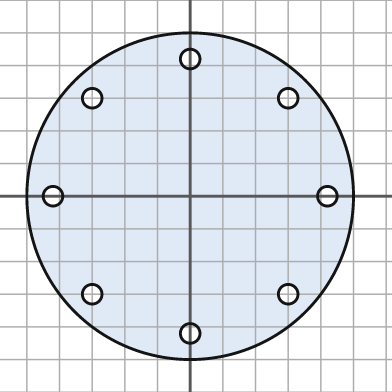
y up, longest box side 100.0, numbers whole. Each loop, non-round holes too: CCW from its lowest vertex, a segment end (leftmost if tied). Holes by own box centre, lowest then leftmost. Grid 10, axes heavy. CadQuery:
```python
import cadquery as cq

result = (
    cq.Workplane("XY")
    .moveTo(0.0, 0.0)
    .circle(50.0)
    .moveTo(0.0, -42.0)
    .circle(3.0)
    .moveTo(-30.0, -30.0)
    .circle(3.0)
    .moveTo(30.0, -30.0)
    .circle(3.0)
    .moveTo(-42.0, 0.0)
    .circle(3.0)
    .moveTo(42.0, 0.0)
    .circle(3.0)
    .moveTo(-30.0, 30.0)
    .circle(3.0)
    .moveTo(30.0, 30.0)
    .circle(3.0)
    .moveTo(0.0, 42.0)
    .circle(3.0)
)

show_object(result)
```